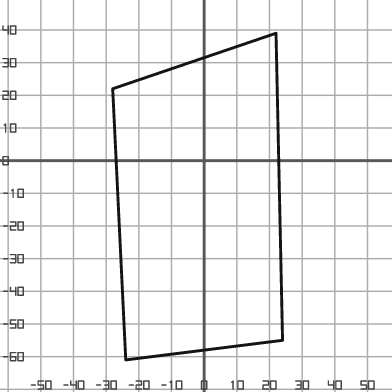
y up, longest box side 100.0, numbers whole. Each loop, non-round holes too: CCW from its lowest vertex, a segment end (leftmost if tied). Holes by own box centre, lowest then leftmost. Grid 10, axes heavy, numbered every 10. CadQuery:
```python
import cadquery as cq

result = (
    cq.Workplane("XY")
    .moveTo(-24.0, -61.0)
    .lineTo(24.0, -55.0)
    .lineTo(22.0, 39.0)
    .lineTo(-28.0, 22.0)
    .close()
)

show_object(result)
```